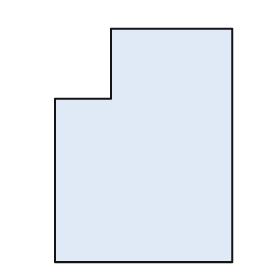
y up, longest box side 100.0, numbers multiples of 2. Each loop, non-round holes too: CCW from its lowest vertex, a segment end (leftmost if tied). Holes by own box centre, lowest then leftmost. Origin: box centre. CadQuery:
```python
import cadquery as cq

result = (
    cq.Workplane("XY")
    .moveTo(-38.0, -50.0)
    .lineTo(38.0, -50.0)
    .lineTo(38.0, 50.0)
    .lineTo(-14.0, 50.0)
    .lineTo(-14.0, 20.0)
    .lineTo(-38.0, 20.0)
    .close()
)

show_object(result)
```